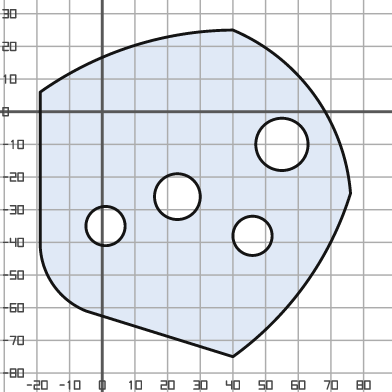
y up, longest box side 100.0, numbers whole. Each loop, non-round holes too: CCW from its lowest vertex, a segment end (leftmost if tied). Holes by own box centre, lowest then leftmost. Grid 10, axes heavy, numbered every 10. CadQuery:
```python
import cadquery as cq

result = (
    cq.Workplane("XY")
    .moveTo(40.0, -75.0)
    .threePointArc((62.0, -53.0), (76.0, -25.0))
    .threePointArc((65.0, 5.0), (40.0, 25.0))
    .threePointArc((9.0, 20.0), (-19.0, 6.0))
    .lineTo(-19.0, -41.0)
    .threePointArc((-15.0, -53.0), (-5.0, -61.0))
    .close()
    .moveTo(46.0, -38.0)
    .circle(6.0)
    .moveTo(1.0, -35.0)
    .circle(6.0)
    .moveTo(23.0, -26.0)
    .circle(7.0)
    .moveTo(55.0, -10.0)
    .circle(8.0)
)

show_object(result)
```